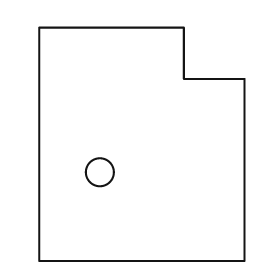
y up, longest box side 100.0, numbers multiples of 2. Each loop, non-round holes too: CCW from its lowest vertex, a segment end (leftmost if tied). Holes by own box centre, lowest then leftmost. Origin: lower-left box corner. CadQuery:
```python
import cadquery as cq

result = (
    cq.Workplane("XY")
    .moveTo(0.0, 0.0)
    .lineTo(88.0, 0.0)
    .lineTo(88.0, 78.0)
    .lineTo(62.0, 78.0)
    .lineTo(62.0, 100.0)
    .lineTo(0.0, 100.0)
    .close()
    .moveTo(26.0, 38.0)
    .circle(6.0)
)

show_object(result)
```